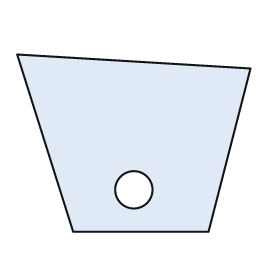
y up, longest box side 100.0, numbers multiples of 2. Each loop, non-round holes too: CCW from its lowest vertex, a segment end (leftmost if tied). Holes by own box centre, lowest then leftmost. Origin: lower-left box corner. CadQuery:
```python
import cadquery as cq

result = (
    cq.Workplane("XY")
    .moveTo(24.0, 0.0)
    .lineTo(82.0, 0.0)
    .lineTo(100.0, 70.0)
    .lineTo(0.0, 76.0)
    .close()
    .moveTo(50.0, 18.0)
    .circle(8.0)
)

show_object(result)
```